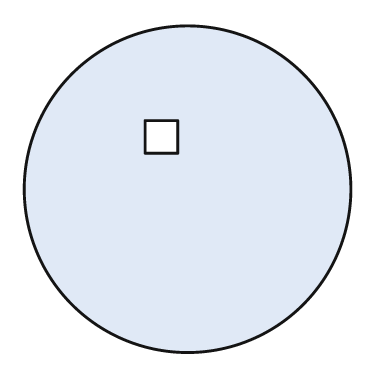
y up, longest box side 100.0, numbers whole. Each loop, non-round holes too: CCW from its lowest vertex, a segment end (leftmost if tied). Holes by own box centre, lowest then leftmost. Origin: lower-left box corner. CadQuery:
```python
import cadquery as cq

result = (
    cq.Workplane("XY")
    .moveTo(50.0, 50.0)
    .circle(50.0)
    .moveTo(37.0, 61.0)
    .lineTo(47.0, 61.0)
    .lineTo(47.0, 71.0)
    .lineTo(37.0, 71.0)
    .close()
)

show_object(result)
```